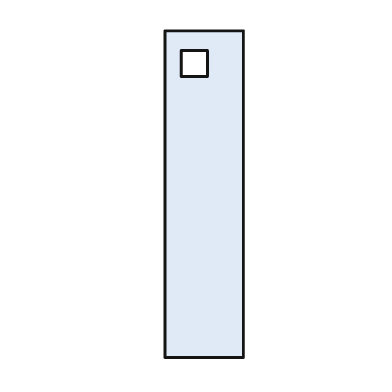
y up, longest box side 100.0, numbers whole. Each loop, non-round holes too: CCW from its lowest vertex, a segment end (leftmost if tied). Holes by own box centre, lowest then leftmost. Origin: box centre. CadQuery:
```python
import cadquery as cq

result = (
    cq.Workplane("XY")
    .moveTo(-12.0, -50.0)
    .lineTo(12.0, -50.0)
    .lineTo(12.0, 50.0)
    .lineTo(-12.0, 50.0)
    .close()
    .moveTo(-7.0, 36.0)
    .lineTo(1.0, 36.0)
    .lineTo(1.0, 44.0)
    .lineTo(-7.0, 44.0)
    .close()
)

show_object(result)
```